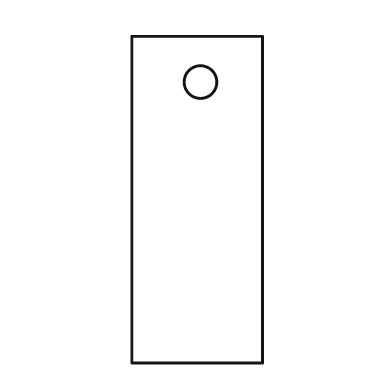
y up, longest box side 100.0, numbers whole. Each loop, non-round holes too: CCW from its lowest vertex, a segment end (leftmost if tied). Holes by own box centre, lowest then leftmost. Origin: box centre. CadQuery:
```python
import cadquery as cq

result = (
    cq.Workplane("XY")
    .moveTo(-20.0, -50.0)
    .lineTo(20.0, -50.0)
    .lineTo(20.0, 50.0)
    .lineTo(-20.0, 50.0)
    .close()
    .moveTo(1.0, 36.0)
    .circle(5.0)
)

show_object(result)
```